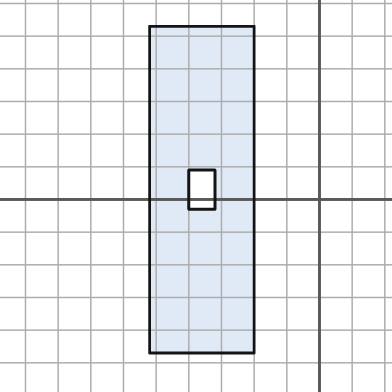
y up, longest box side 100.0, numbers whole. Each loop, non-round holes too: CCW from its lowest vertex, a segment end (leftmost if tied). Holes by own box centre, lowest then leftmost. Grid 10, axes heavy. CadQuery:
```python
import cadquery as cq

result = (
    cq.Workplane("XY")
    .moveTo(-52.0, -47.0)
    .lineTo(-20.0, -47.0)
    .lineTo(-20.0, 53.0)
    .lineTo(-52.0, 53.0)
    .close()
    .moveTo(-40.0, -3.0)
    .lineTo(-32.0, -3.0)
    .lineTo(-32.0, 9.0)
    .lineTo(-40.0, 9.0)
    .close()
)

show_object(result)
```